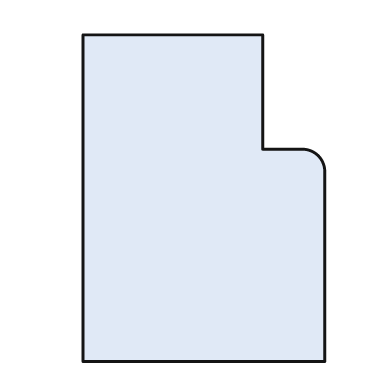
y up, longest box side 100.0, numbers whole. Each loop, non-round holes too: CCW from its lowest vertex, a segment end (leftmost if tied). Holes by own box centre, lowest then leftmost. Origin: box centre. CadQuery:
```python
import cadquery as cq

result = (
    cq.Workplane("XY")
    .moveTo(-37.0, -50.0)
    .lineTo(37.0, -50.0)
    .lineTo(37.0, 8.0)
    .threePointArc((35.0, 13.0), (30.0, 15.0))
    .lineTo(18.0, 15.0)
    .lineTo(18.0, 50.0)
    .lineTo(-37.0, 50.0)
    .close()
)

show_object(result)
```